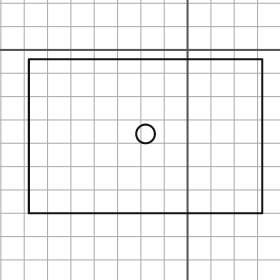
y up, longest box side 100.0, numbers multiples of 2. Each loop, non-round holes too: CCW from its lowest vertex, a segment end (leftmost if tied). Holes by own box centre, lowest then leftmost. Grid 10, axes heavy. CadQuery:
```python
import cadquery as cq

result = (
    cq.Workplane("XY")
    .moveTo(-68.0, -70.0)
    .lineTo(32.0, -70.0)
    .lineTo(32.0, -4.0)
    .lineTo(-68.0, -4.0)
    .close()
    .moveTo(-18.0, -36.0)
    .circle(4.0)
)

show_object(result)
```